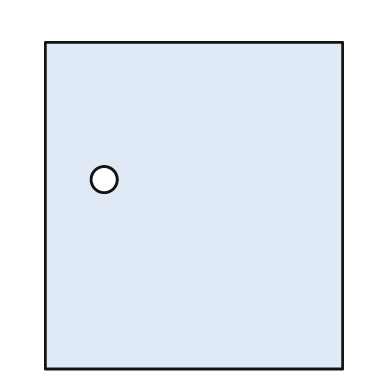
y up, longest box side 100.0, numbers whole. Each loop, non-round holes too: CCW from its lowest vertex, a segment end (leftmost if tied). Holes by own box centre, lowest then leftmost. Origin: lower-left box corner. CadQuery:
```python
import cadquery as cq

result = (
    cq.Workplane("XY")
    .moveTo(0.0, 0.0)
    .lineTo(91.0, 0.0)
    .lineTo(91.0, 100.0)
    .lineTo(0.0, 100.0)
    .close()
    .moveTo(18.0, 58.0)
    .circle(4.0)
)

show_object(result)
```